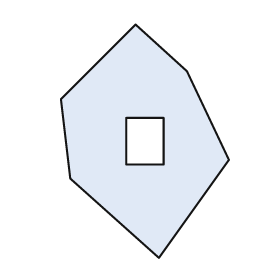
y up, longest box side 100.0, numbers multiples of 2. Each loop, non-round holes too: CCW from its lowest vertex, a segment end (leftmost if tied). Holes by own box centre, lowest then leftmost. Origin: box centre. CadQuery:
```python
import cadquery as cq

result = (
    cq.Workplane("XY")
    .moveTo(6.0, -50.0)
    .lineTo(36.0, -8.0)
    .lineTo(18.0, 30.0)
    .lineTo(-4.0, 50.0)
    .lineTo(-36.0, 18.0)
    .lineTo(-32.0, -16.0)
    .close()
    .moveTo(-8.0, -10.0)
    .lineTo(8.0, -10.0)
    .lineTo(8.0, 10.0)
    .lineTo(-8.0, 10.0)
    .close()
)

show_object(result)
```